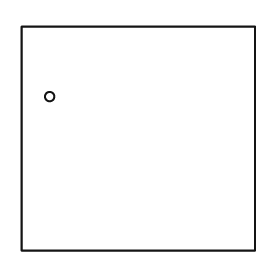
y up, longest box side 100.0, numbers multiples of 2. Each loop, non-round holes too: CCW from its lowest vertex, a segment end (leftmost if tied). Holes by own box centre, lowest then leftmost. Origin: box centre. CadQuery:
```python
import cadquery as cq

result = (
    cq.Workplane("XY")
    .moveTo(-50.0, -48.0)
    .lineTo(50.0, -48.0)
    .lineTo(50.0, 48.0)
    .lineTo(-50.0, 48.0)
    .close()
    .moveTo(-38.0, 18.0)
    .circle(2.0)
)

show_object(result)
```